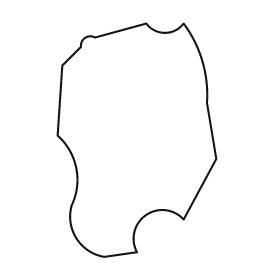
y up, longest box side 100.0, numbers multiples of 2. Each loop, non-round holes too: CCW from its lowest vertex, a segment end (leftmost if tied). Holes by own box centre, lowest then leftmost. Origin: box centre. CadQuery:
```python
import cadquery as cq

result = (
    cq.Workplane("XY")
    .moveTo(-14.0, -50.0)
    .lineTo(0.0, -48.0)
    .threePointArc((4.0, -32.0), (20.0, -34.0))
    .lineTo(34.0, -8.0)
    .lineTo(30.0, 16.0)
    .threePointArc((28.0, 34.0), (20.0, 50.0))
    .threePointArc((12.0, 46.0), (4.0, 50.0))
    .lineTo(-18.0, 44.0)
    .threePointArc((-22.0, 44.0), (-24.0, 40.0))
    .lineTo(-32.0, 32.0)
    .lineTo(-34.0, 2.0)
    .threePointArc((-26.0, -12.0), (-28.0, -28.0))
    .threePointArc((-26.0, -42.0), (-14.0, -50.0))
    .close()
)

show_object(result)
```